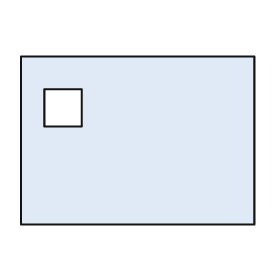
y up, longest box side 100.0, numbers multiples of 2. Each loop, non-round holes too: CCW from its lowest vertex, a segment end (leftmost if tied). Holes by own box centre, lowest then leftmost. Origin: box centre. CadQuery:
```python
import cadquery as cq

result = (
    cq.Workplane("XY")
    .moveTo(-50.0, -36.0)
    .lineTo(50.0, -36.0)
    .lineTo(50.0, 36.0)
    .lineTo(-50.0, 36.0)
    .close()
    .moveTo(-40.0, 6.0)
    .lineTo(-24.0, 6.0)
    .lineTo(-24.0, 22.0)
    .lineTo(-40.0, 22.0)
    .close()
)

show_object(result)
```